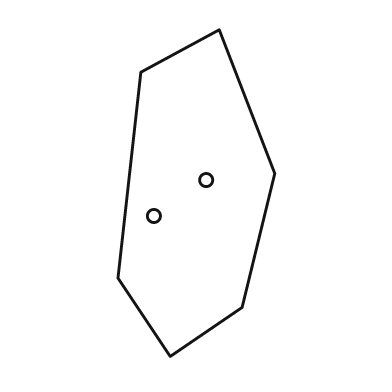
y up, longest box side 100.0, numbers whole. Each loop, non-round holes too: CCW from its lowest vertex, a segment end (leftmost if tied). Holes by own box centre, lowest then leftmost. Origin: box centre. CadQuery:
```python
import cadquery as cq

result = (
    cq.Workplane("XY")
    .moveTo(-8.0, -50.0)
    .lineTo(14.0, -35.0)
    .lineTo(24.0, 6.0)
    .lineTo(7.0, 50.0)
    .lineTo(-17.0, 37.0)
    .lineTo(-24.0, -26.0)
    .close()
    .moveTo(-13.0, -7.0)
    .circle(2.0)
    .moveTo(3.0, 4.0)
    .circle(2.0)
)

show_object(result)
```